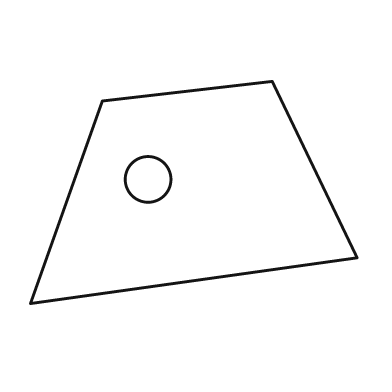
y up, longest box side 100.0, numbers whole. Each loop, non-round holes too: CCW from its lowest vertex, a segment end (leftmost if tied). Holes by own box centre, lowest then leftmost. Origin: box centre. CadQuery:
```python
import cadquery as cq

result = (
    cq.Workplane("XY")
    .moveTo(-50.0, -34.0)
    .lineTo(50.0, -20.0)
    .lineTo(24.0, 34.0)
    .lineTo(-28.0, 28.0)
    .close()
    .moveTo(-14.0, 4.0)
    .circle(7.0)
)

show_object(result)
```